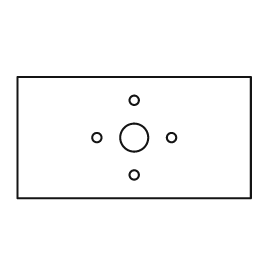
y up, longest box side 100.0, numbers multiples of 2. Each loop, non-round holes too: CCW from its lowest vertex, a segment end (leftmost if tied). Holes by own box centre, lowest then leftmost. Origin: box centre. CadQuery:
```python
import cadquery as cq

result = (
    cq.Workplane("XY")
    .moveTo(-50.0, -26.0)
    .lineTo(50.0, -26.0)
    .lineTo(50.0, 26.0)
    .lineTo(-50.0, 26.0)
    .close()
    .moveTo(0.0, -16.0)
    .circle(2.0)
    .moveTo(-16.0, 0.0)
    .circle(2.0)
    .moveTo(0.0, 0.0)
    .circle(6.0)
    .moveTo(16.0, 0.0)
    .circle(2.0)
    .moveTo(0.0, 16.0)
    .circle(2.0)
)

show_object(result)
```